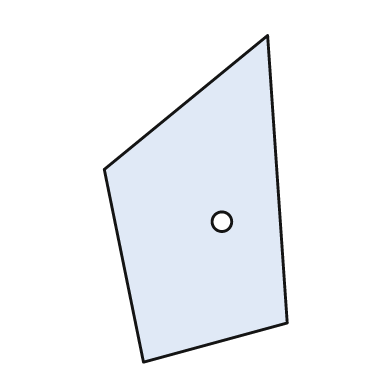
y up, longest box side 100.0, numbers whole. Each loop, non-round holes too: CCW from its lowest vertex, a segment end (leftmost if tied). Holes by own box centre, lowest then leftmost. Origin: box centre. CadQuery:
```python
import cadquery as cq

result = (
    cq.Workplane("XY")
    .moveTo(-16.0, -50.0)
    .lineTo(28.0, -38.0)
    .lineTo(22.0, 50.0)
    .lineTo(-28.0, 9.0)
    .close()
    .moveTo(8.0, -7.0)
    .circle(3.0)
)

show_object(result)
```